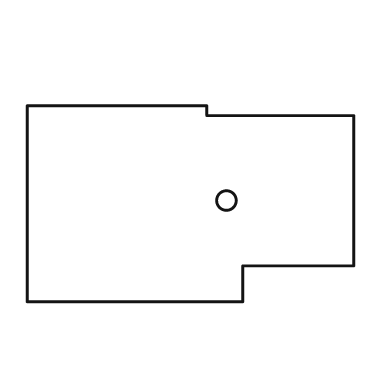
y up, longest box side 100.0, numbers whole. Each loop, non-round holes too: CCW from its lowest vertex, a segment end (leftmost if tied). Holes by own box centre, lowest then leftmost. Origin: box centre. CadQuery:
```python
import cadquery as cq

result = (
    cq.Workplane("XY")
    .moveTo(-50.0, -30.0)
    .lineTo(16.0, -30.0)
    .lineTo(16.0, -19.0)
    .lineTo(50.0, -19.0)
    .lineTo(50.0, 27.0)
    .lineTo(5.0, 27.0)
    .lineTo(5.0, 30.0)
    .lineTo(-50.0, 30.0)
    .close()
    .moveTo(11.0, 1.0)
    .circle(3.0)
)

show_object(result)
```